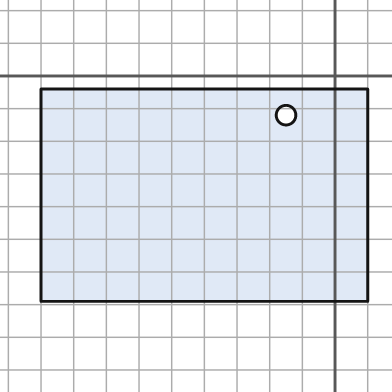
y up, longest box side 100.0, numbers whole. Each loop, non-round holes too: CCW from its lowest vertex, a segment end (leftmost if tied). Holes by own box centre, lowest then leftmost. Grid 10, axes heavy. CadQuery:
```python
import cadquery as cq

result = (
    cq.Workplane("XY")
    .moveTo(-90.0, -69.0)
    .lineTo(10.0, -69.0)
    .lineTo(10.0, -4.0)
    .lineTo(-90.0, -4.0)
    .close()
    .moveTo(-15.0, -12.0)
    .circle(3.0)
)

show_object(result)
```